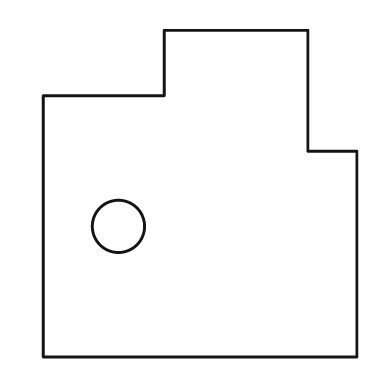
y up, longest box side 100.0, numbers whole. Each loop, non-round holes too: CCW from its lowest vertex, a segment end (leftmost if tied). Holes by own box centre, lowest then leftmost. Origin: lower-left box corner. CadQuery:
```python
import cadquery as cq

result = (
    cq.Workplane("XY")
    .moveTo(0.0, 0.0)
    .lineTo(96.0, 0.0)
    .lineTo(96.0, 63.0)
    .lineTo(81.0, 63.0)
    .lineTo(81.0, 100.0)
    .lineTo(37.0, 100.0)
    .lineTo(37.0, 80.0)
    .lineTo(0.0, 80.0)
    .close()
    .moveTo(23.0, 40.0)
    .circle(8.0)
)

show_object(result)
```